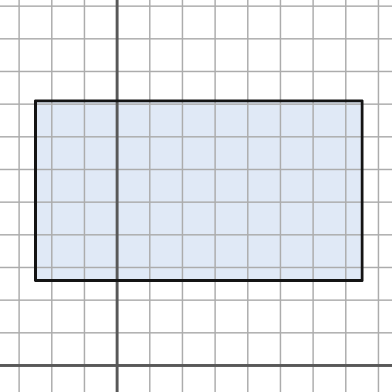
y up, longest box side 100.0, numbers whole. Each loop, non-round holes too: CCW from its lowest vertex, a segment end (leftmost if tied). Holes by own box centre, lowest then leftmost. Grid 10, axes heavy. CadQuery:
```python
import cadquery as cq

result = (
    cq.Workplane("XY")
    .moveTo(-25.0, 26.0)
    .lineTo(75.0, 26.0)
    .lineTo(75.0, 81.0)
    .lineTo(-25.0, 81.0)
    .close()
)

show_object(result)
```